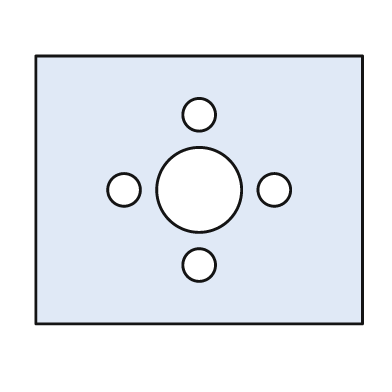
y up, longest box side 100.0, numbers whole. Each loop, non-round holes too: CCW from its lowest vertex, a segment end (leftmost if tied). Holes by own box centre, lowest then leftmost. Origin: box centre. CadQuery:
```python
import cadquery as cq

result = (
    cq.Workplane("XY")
    .moveTo(-50.0, -41.0)
    .lineTo(50.0, -41.0)
    .lineTo(50.0, 41.0)
    .lineTo(-50.0, 41.0)
    .close()
    .moveTo(0.0, -23.0)
    .circle(5.0)
    .moveTo(-23.0, 0.0)
    .circle(5.0)
    .moveTo(0.0, 0.0)
    .circle(13.0)
    .moveTo(23.0, 0.0)
    .circle(5.0)
    .moveTo(0.0, 23.0)
    .circle(5.0)
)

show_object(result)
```